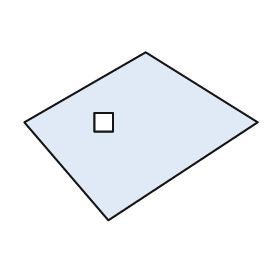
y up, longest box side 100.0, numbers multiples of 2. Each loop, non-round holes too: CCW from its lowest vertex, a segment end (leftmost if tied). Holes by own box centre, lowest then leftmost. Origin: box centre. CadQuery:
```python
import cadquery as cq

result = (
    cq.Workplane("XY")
    .moveTo(-14.0, -36.0)
    .lineTo(50.0, 6.0)
    .lineTo(2.0, 36.0)
    .lineTo(-50.0, 6.0)
    .close()
    .moveTo(-20.0, 2.0)
    .lineTo(-12.0, 2.0)
    .lineTo(-12.0, 10.0)
    .lineTo(-20.0, 10.0)
    .close()
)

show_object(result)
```